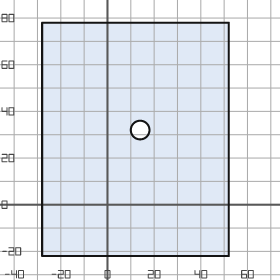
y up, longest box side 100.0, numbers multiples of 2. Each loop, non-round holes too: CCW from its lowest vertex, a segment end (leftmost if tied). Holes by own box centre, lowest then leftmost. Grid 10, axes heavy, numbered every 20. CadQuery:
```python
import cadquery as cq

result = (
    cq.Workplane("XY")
    .moveTo(-28.0, -22.0)
    .lineTo(52.0, -22.0)
    .lineTo(52.0, 78.0)
    .lineTo(-28.0, 78.0)
    .close()
    .moveTo(14.0, 32.0)
    .circle(4.0)
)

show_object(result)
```